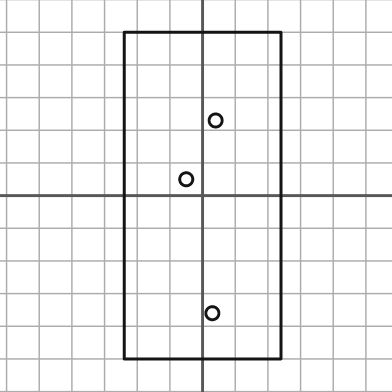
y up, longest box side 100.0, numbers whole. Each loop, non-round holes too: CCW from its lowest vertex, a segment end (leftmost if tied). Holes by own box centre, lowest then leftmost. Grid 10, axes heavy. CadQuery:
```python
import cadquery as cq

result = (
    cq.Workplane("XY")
    .moveTo(-24.0, -50.0)
    .lineTo(24.0, -50.0)
    .lineTo(24.0, 50.0)
    .lineTo(-24.0, 50.0)
    .close()
    .moveTo(3.0, -36.0)
    .circle(2.0)
    .moveTo(-5.0, 5.0)
    .circle(2.0)
    .moveTo(4.0, 23.0)
    .circle(2.0)
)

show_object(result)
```